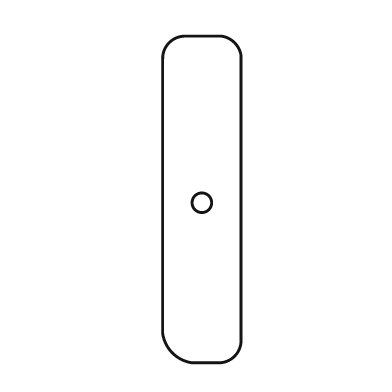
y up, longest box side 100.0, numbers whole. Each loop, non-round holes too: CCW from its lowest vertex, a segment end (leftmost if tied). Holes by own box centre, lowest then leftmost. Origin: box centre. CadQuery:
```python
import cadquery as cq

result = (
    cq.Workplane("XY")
    .moveTo(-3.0, -50.0)
    .lineTo(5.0, -50.0)
    .threePointArc((10.0, -48.0), (12.0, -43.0))
    .lineTo(12.0, 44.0)
    .threePointArc((10.0, 48.0), (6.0, 50.0))
    .lineTo(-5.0, 50.0)
    .threePointArc((-10.0, 48.0), (-12.0, 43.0))
    .lineTo(-12.0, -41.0)
    .threePointArc((-9.0, -47.0), (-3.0, -50.0))
    .close()
    .moveTo(0.0, -1.0)
    .circle(3.0)
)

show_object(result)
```